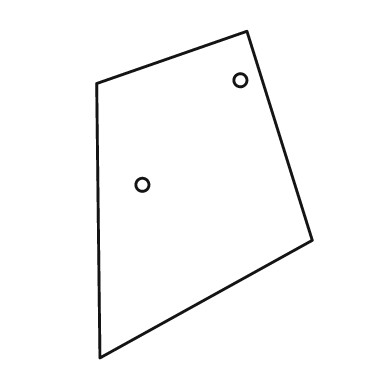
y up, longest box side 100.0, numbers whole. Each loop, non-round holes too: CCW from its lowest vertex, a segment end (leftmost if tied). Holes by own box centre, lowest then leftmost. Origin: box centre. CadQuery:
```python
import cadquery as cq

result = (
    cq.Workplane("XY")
    .moveTo(-32.0, -50.0)
    .lineTo(33.0, -14.0)
    .lineTo(13.0, 50.0)
    .lineTo(-33.0, 34.0)
    .close()
    .moveTo(-19.0, 3.0)
    .circle(2.0)
    .moveTo(11.0, 35.0)
    .circle(2.0)
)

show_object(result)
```